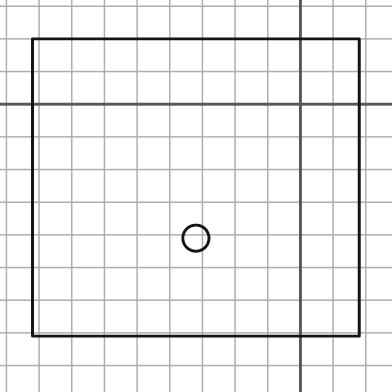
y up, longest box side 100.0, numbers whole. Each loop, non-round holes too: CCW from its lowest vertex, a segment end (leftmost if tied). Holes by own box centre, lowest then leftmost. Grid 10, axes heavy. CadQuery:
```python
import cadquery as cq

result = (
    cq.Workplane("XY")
    .moveTo(-82.0, -71.0)
    .lineTo(18.0, -71.0)
    .lineTo(18.0, 20.0)
    .lineTo(-82.0, 20.0)
    .close()
    .moveTo(-32.0, -41.0)
    .circle(4.0)
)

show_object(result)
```